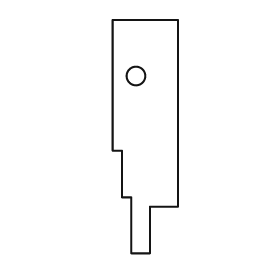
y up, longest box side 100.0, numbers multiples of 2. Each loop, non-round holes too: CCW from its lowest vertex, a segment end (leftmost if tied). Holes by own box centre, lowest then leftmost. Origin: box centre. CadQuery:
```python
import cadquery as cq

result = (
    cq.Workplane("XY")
    .moveTo(-6.0, -50.0)
    .lineTo(2.0, -50.0)
    .lineTo(2.0, -30.0)
    .lineTo(14.0, -30.0)
    .lineTo(14.0, 50.0)
    .lineTo(-14.0, 50.0)
    .lineTo(-14.0, -6.0)
    .lineTo(-10.0, -6.0)
    .lineTo(-10.0, -26.0)
    .lineTo(-6.0, -26.0)
    .close()
    .moveTo(-4.0, 26.0)
    .circle(4.0)
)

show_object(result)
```